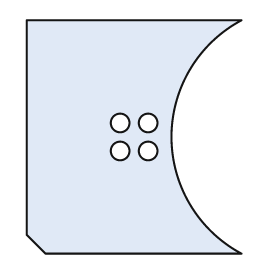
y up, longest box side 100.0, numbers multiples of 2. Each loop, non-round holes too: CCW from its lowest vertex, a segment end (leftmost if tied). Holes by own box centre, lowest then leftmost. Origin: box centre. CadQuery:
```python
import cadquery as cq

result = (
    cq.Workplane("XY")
    .moveTo(-38.0, -50.0)
    .lineTo(46.0, -50.0)
    .threePointArc((16.0, 0.0), (46.0, 50.0))
    .lineTo(-46.0, 50.0)
    .lineTo(-46.0, -42.0)
    .close()
    .moveTo(-6.0, -6.0)
    .circle(4.0)
    .moveTo(6.0, -6.0)
    .circle(4.0)
    .moveTo(-6.0, 6.0)
    .circle(4.0)
    .moveTo(6.0, 6.0)
    .circle(4.0)
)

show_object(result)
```